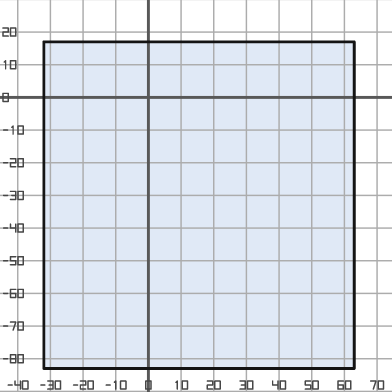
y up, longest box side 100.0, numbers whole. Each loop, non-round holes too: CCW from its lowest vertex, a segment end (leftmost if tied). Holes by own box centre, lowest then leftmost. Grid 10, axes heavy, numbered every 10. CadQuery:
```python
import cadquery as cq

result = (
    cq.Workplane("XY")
    .moveTo(-32.0, -83.0)
    .lineTo(63.0, -83.0)
    .lineTo(63.0, 17.0)
    .lineTo(-32.0, 17.0)
    .close()
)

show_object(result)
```